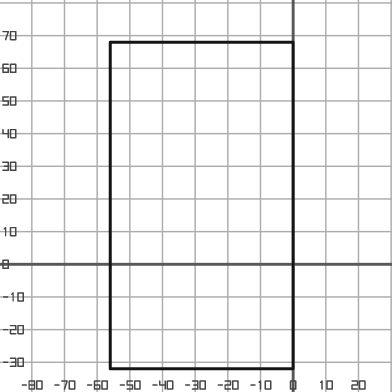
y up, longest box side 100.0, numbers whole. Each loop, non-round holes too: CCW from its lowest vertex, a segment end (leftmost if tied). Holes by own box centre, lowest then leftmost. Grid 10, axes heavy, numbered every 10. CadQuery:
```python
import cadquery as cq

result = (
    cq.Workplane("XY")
    .moveTo(-56.0, -32.0)
    .lineTo(0.0, -32.0)
    .lineTo(0.0, 68.0)
    .lineTo(-56.0, 68.0)
    .close()
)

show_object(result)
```